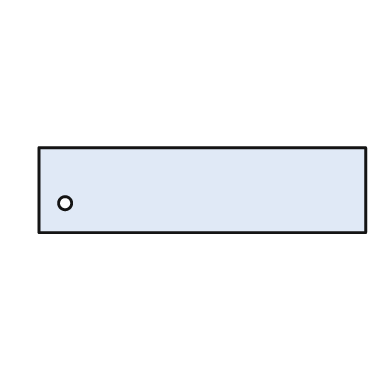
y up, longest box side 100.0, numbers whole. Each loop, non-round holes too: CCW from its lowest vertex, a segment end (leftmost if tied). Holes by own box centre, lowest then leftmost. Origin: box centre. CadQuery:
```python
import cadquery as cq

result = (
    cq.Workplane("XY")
    .moveTo(-50.0, -13.0)
    .lineTo(50.0, -13.0)
    .lineTo(50.0, 13.0)
    .lineTo(-50.0, 13.0)
    .close()
    .moveTo(-42.0, -4.0)
    .circle(2.0)
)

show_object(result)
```